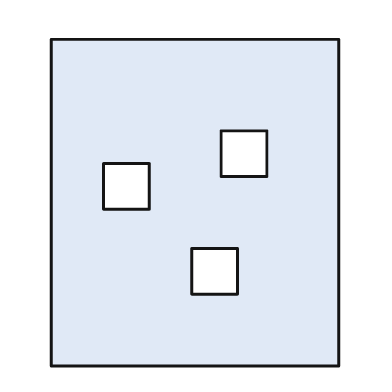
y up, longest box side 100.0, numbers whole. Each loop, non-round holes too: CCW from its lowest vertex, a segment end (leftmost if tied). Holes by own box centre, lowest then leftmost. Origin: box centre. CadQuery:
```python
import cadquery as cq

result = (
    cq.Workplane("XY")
    .moveTo(-44.0, -50.0)
    .lineTo(44.0, -50.0)
    .lineTo(44.0, 50.0)
    .lineTo(-44.0, 50.0)
    .close()
    .moveTo(-1.0, -28.0)
    .lineTo(13.0, -28.0)
    .lineTo(13.0, -14.0)
    .lineTo(-1.0, -14.0)
    .close()
    .moveTo(-28.0, -2.0)
    .lineTo(-14.0, -2.0)
    .lineTo(-14.0, 12.0)
    .lineTo(-28.0, 12.0)
    .close()
    .moveTo(8.0, 8.0)
    .lineTo(22.0, 8.0)
    .lineTo(22.0, 22.0)
    .lineTo(8.0, 22.0)
    .close()
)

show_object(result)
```